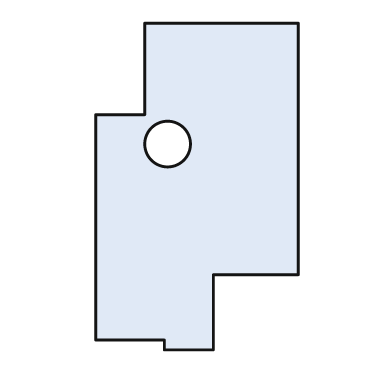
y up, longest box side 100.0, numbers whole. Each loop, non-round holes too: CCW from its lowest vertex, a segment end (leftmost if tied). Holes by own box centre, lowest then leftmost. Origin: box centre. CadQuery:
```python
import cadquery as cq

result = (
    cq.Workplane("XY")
    .moveTo(-10.0, -50.0)
    .lineTo(5.0, -50.0)
    .lineTo(5.0, -27.0)
    .lineTo(31.0, -27.0)
    .lineTo(31.0, 50.0)
    .lineTo(-16.0, 50.0)
    .lineTo(-16.0, 22.0)
    .lineTo(-31.0, 22.0)
    .lineTo(-31.0, -47.0)
    .lineTo(-10.0, -47.0)
    .close()
    .moveTo(-9.0, 13.0)
    .circle(7.0)
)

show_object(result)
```